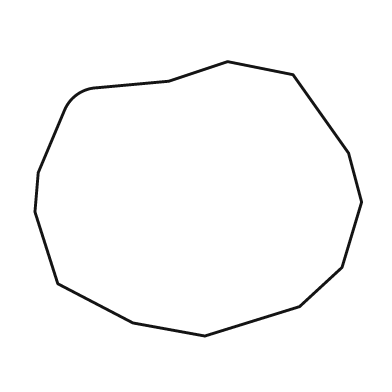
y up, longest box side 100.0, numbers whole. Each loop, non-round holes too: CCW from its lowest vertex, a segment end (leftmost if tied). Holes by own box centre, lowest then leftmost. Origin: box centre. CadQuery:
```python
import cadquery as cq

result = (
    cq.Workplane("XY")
    .moveTo(2.0, -42.0)
    .lineTo(31.0, -33.0)
    .lineTo(44.0, -21.0)
    .lineTo(50.0, -1.0)
    .lineTo(46.0, 14.0)
    .lineTo(29.0, 38.0)
    .lineTo(9.0, 42.0)
    .lineTo(-9.0, 36.0)
    .lineTo(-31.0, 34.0)
    .threePointArc((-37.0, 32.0), (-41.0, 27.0))
    .lineTo(-49.0, 8.0)
    .lineTo(-50.0, -4.0)
    .lineTo(-43.0, -26.0)
    .lineTo(-20.0, -38.0)
    .close()
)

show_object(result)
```